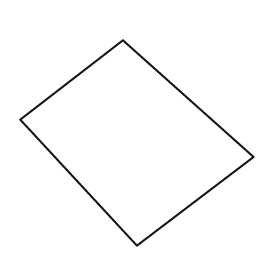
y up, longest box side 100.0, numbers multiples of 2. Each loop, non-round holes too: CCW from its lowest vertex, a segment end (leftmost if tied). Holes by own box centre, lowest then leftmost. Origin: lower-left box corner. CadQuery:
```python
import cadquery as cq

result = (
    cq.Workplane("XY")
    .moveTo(50.0, 0.0)
    .lineTo(100.0, 38.0)
    .lineTo(44.0, 88.0)
    .lineTo(0.0, 54.0)
    .close()
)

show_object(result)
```